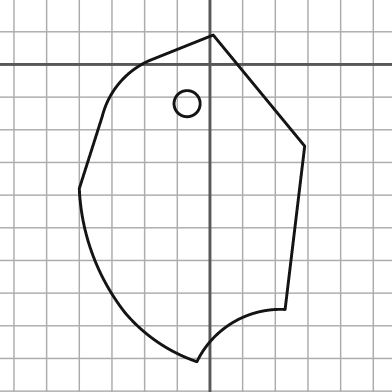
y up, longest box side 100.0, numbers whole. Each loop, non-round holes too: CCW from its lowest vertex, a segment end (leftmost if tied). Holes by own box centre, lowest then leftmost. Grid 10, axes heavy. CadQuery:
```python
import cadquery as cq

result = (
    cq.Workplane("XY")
    .moveTo(-4.0, -91.0)
    .threePointArc((7.0, -79.0), (23.0, -75.0))
    .lineTo(29.0, -25.0)
    .lineTo(1.0, 9.0)
    .lineTo(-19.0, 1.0)
    .threePointArc((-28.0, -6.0), (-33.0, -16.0))
    .lineTo(-40.0, -38.0)
    .threePointArc((-36.0, -58.0), (-26.0, -76.0))
    .threePointArc((-16.0, -85.0), (-4.0, -91.0))
    .close()
    .moveTo(-7.0, -12.0)
    .circle(4.0)
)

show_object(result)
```